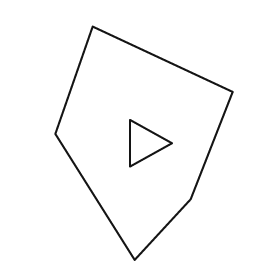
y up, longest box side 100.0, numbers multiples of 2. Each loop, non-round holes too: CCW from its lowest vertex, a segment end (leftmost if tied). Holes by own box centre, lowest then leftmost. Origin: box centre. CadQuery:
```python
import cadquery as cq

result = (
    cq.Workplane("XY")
    .moveTo(-4.0, -50.0)
    .lineTo(20.0, -24.0)
    .lineTo(38.0, 22.0)
    .lineTo(-22.0, 50.0)
    .lineTo(-38.0, 4.0)
    .close()
    .moveTo(-6.0, -10.0)
    .lineTo(12.0, 0.0)
    .lineTo(-6.0, 10.0)
    .close()
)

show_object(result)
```